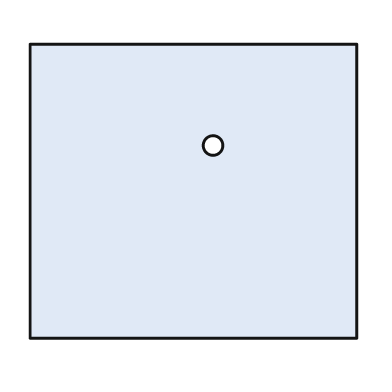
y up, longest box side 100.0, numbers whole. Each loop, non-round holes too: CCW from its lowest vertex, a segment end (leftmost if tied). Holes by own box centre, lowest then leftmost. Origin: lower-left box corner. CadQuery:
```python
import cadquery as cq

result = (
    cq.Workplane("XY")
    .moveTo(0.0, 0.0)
    .lineTo(100.0, 0.0)
    .lineTo(100.0, 90.0)
    .lineTo(0.0, 90.0)
    .close()
    .moveTo(56.0, 59.0)
    .circle(3.0)
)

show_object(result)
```